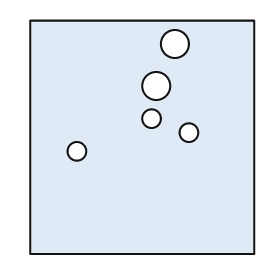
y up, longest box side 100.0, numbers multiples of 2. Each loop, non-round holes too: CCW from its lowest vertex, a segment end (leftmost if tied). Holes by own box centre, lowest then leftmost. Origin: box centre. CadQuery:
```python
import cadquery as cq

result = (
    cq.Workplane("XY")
    .moveTo(-48.0, -50.0)
    .lineTo(48.0, -50.0)
    .lineTo(48.0, 50.0)
    .lineTo(-48.0, 50.0)
    .close()
    .moveTo(-28.0, -6.0)
    .circle(4.0)
    .moveTo(20.0, 2.0)
    .circle(4.0)
    .moveTo(4.0, 8.0)
    .circle(4.0)
    .moveTo(6.0, 22.0)
    .circle(6.0)
    .moveTo(14.0, 40.0)
    .circle(6.0)
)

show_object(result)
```